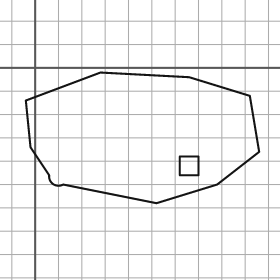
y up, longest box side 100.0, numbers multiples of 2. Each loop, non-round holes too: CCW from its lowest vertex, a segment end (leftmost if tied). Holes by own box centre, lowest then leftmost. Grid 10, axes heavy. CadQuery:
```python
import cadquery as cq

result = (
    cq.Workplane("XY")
    .moveTo(52.0, -58.0)
    .lineTo(78.0, -50.0)
    .lineTo(96.0, -36.0)
    .lineTo(92.0, -12.0)
    .lineTo(66.0, -4.0)
    .lineTo(28.0, -2.0)
    .lineTo(-4.0, -14.0)
    .lineTo(-2.0, -34.0)
    .lineTo(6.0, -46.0)
    .threePointArc((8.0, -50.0), (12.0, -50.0))
    .close()
    .moveTo(62.0, -46.0)
    .lineTo(70.0, -46.0)
    .lineTo(70.0, -38.0)
    .lineTo(62.0, -38.0)
    .close()
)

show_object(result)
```